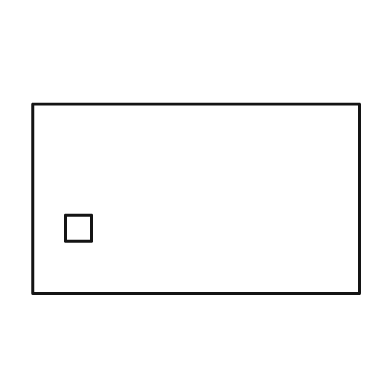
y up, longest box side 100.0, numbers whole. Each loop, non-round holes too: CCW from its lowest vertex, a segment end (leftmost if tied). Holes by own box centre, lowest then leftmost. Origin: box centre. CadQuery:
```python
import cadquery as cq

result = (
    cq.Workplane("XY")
    .moveTo(-50.0, -29.0)
    .lineTo(50.0, -29.0)
    .lineTo(50.0, 29.0)
    .lineTo(-50.0, 29.0)
    .close()
    .moveTo(-40.0, -13.0)
    .lineTo(-32.0, -13.0)
    .lineTo(-32.0, -5.0)
    .lineTo(-40.0, -5.0)
    .close()
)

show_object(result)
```